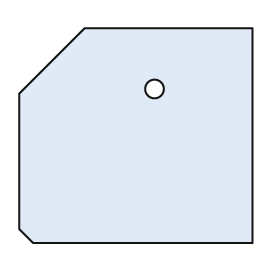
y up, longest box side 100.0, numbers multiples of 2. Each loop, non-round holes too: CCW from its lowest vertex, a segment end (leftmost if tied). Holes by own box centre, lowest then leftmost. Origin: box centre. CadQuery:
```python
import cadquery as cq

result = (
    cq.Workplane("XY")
    .moveTo(-44.0, -46.0)
    .lineTo(50.0, -46.0)
    .lineTo(50.0, 46.0)
    .lineTo(-22.0, 46.0)
    .lineTo(-50.0, 18.0)
    .lineTo(-50.0, -40.0)
    .close()
    .moveTo(8.0, 20.0)
    .circle(4.0)
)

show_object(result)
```